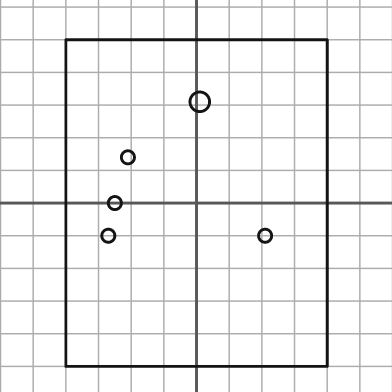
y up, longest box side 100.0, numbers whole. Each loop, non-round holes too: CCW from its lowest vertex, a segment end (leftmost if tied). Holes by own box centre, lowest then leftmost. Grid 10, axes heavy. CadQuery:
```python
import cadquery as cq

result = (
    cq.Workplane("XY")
    .moveTo(-40.0, -50.0)
    .lineTo(40.0, -50.0)
    .lineTo(40.0, 50.0)
    .lineTo(-40.0, 50.0)
    .close()
    .moveTo(-27.0, -10.0)
    .circle(2.0)
    .moveTo(21.0, -10.0)
    .circle(2.0)
    .moveTo(-25.0, 0.0)
    .circle(2.0)
    .moveTo(-21.0, 14.0)
    .circle(2.0)
    .moveTo(1.0, 31.0)
    .circle(3.0)
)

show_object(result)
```